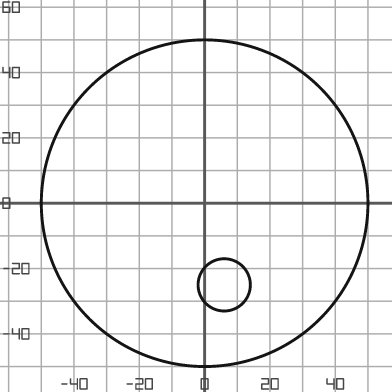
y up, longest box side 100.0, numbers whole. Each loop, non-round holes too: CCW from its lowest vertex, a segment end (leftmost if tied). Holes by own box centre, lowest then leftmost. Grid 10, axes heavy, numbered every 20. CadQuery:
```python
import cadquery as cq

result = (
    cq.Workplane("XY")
    .moveTo(0.0, 0.0)
    .circle(50.0)
    .moveTo(6.0, -25.0)
    .circle(8.0)
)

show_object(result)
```